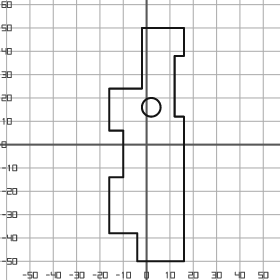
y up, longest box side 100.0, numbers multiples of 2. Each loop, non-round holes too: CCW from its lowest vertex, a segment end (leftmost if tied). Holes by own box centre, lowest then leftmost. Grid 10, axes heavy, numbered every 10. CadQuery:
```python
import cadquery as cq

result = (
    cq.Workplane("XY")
    .moveTo(-4.0, -50.0)
    .lineTo(16.0, -50.0)
    .lineTo(16.0, 12.0)
    .lineTo(12.0, 12.0)
    .lineTo(12.0, 38.0)
    .lineTo(16.0, 38.0)
    .lineTo(16.0, 50.0)
    .lineTo(-2.0, 50.0)
    .lineTo(-2.0, 24.0)
    .lineTo(-16.0, 24.0)
    .lineTo(-16.0, 6.0)
    .lineTo(-10.0, 6.0)
    .lineTo(-10.0, -14.0)
    .lineTo(-16.0, -14.0)
    .lineTo(-16.0, -38.0)
    .lineTo(-4.0, -38.0)
    .close()
    .moveTo(2.0, 16.0)
    .circle(4.0)
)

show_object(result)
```